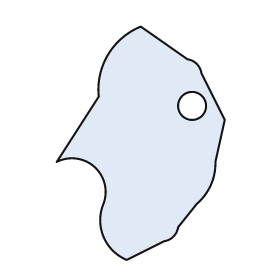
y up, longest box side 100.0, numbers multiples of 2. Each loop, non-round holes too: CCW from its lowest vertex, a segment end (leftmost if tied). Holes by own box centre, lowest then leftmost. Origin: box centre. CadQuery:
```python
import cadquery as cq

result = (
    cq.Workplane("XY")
    .moveTo(-6.0, -50.0)
    .lineTo(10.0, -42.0)
    .threePointArc((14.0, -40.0), (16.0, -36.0))
    .lineTo(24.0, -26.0)
    .threePointArc((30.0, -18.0), (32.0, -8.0))
    .lineTo(36.0, 10.0)
    .lineTo(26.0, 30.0)
    .threePointArc((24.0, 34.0), (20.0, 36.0))
    .lineTo(0.0, 50.0)
    .threePointArc((-14.0, 38.0), (-18.0, 20.0))
    .lineTo(-36.0, -8.0)
    .threePointArc((-20.0, -10.0), (-16.0, -26.0))
    .threePointArc((-16.0, -40.0), (-6.0, -50.0))
    .close()
    .moveTo(22.0, 16.0)
    .circle(6.0)
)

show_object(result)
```